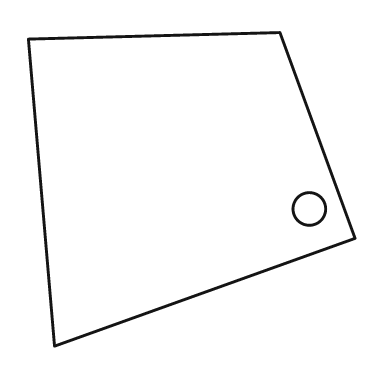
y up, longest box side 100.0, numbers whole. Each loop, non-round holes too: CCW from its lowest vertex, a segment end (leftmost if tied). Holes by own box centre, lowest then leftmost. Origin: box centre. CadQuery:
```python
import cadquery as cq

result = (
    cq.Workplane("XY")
    .moveTo(-42.0, -48.0)
    .lineTo(50.0, -15.0)
    .lineTo(27.0, 48.0)
    .lineTo(-50.0, 46.0)
    .close()
    .moveTo(36.0, -6.0)
    .circle(5.0)
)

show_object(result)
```